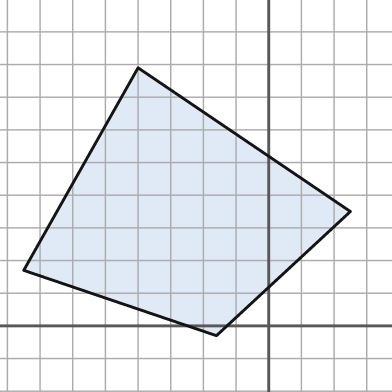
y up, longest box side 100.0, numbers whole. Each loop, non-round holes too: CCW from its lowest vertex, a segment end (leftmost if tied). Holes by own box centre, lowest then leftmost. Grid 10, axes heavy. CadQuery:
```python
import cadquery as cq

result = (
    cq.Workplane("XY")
    .moveTo(-16.0, -3.0)
    .lineTo(25.0, 35.0)
    .lineTo(-40.0, 79.0)
    .lineTo(-75.0, 17.0)
    .close()
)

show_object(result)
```